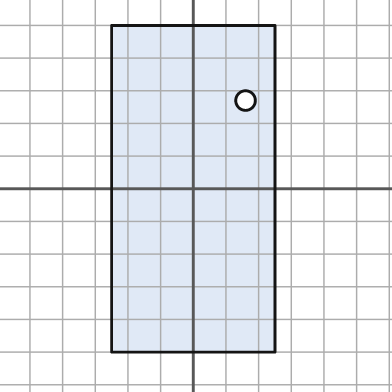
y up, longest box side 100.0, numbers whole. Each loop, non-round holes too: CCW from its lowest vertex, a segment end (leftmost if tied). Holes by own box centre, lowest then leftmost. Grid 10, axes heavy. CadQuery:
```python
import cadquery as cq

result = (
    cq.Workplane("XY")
    .moveTo(-25.0, -50.0)
    .lineTo(25.0, -50.0)
    .lineTo(25.0, 50.0)
    .lineTo(-25.0, 50.0)
    .close()
    .moveTo(16.0, 27.0)
    .circle(3.0)
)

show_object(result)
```